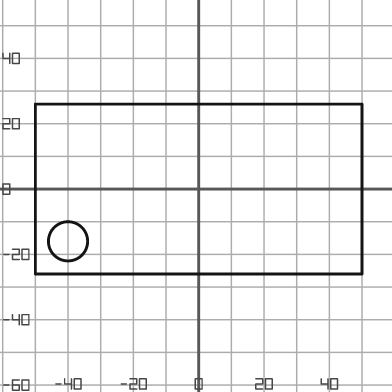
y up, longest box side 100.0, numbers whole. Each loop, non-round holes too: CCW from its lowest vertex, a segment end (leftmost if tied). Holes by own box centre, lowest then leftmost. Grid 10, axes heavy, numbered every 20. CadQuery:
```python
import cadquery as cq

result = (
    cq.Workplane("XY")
    .moveTo(-50.0, -26.0)
    .lineTo(50.0, -26.0)
    .lineTo(50.0, 26.0)
    .lineTo(-50.0, 26.0)
    .close()
    .moveTo(-40.0, -16.0)
    .circle(6.0)
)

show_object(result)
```